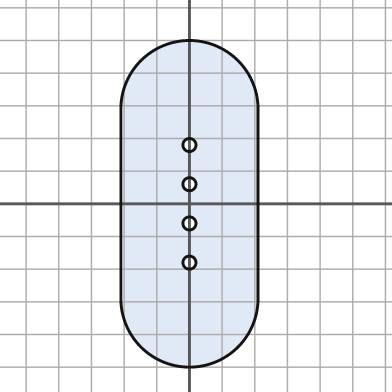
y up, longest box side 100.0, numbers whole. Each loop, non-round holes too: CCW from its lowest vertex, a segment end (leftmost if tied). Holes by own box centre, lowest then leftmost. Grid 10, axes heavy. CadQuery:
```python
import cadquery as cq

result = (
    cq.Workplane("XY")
    .moveTo(-21.0, -29.0)
    .threePointArc((0.0, -50.0), (21.0, -29.0))
    .lineTo(21.0, 29.0)
    .threePointArc((0.0, 50.0), (-21.0, 29.0))
    .close()
    .moveTo(0.0, -18.0)
    .circle(2.0)
    .moveTo(0.0, -6.0)
    .circle(2.0)
    .moveTo(0.0, 6.0)
    .circle(2.0)
    .moveTo(0.0, 18.0)
    .circle(2.0)
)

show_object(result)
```